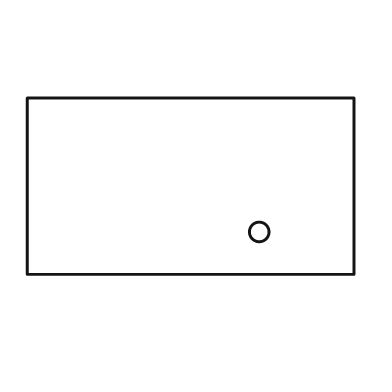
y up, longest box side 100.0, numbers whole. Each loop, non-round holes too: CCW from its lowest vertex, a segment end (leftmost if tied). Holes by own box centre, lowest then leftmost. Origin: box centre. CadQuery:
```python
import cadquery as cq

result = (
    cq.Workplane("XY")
    .moveTo(-50.0, -27.0)
    .lineTo(50.0, -27.0)
    .lineTo(50.0, 27.0)
    .lineTo(-50.0, 27.0)
    .close()
    .moveTo(21.0, -14.0)
    .circle(3.0)
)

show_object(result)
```